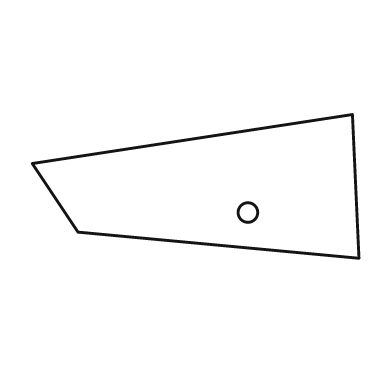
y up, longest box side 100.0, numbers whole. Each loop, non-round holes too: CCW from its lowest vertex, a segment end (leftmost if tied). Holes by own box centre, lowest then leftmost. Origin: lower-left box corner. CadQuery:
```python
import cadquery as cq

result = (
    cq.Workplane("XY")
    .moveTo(100.0, 0.0)
    .lineTo(98.0, 44.0)
    .lineTo(0.0, 29.0)
    .lineTo(14.0, 8.0)
    .close()
    .moveTo(66.0, 14.0)
    .circle(3.0)
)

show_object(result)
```